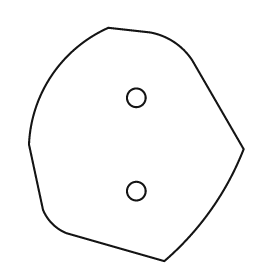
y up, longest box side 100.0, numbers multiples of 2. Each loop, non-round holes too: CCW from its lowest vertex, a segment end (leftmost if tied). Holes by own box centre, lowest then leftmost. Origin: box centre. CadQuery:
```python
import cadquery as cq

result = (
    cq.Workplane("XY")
    .moveTo(12.0, -50.0)
    .threePointArc((32.0, -28.0), (46.0, -2.0))
    .lineTo(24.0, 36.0)
    .threePointArc((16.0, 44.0), (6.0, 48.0))
    .lineTo(-12.0, 50.0)
    .threePointArc((-36.0, 30.0), (-46.0, 0.0))
    .lineTo(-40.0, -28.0)
    .threePointArc((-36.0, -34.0), (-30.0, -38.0))
    .close()
    .moveTo(0.0, -20.0)
    .circle(4.0)
    .moveTo(0.0, 20.0)
    .circle(4.0)
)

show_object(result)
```